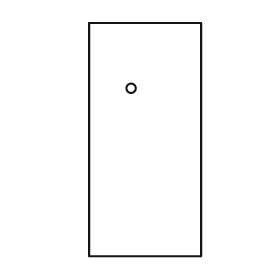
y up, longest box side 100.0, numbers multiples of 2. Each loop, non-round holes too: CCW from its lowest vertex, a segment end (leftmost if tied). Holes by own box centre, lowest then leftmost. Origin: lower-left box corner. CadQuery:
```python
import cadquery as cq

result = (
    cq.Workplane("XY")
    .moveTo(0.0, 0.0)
    .lineTo(48.0, 0.0)
    .lineTo(48.0, 100.0)
    .lineTo(0.0, 100.0)
    .close()
    .moveTo(18.0, 72.0)
    .circle(2.0)
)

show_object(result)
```